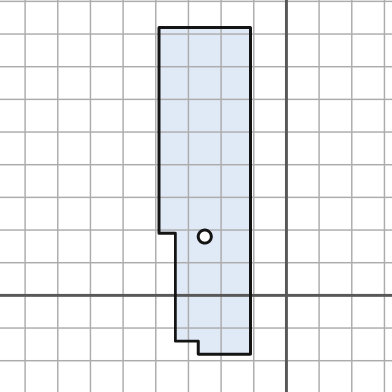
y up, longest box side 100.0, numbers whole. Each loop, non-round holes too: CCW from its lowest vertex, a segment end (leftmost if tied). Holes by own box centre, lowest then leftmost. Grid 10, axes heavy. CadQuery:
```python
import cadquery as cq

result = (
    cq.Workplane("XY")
    .moveTo(-27.0, -18.0)
    .lineTo(-11.0, -18.0)
    .lineTo(-11.0, 82.0)
    .lineTo(-39.0, 82.0)
    .lineTo(-39.0, 19.0)
    .lineTo(-34.0, 19.0)
    .lineTo(-34.0, -14.0)
    .lineTo(-27.0, -14.0)
    .close()
    .moveTo(-25.0, 18.0)
    .circle(2.0)
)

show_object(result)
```